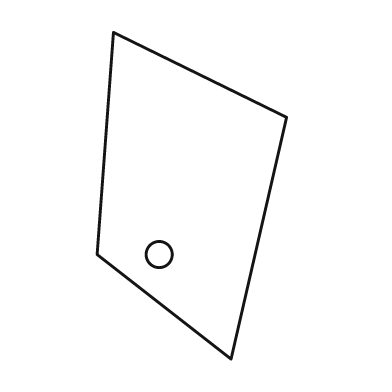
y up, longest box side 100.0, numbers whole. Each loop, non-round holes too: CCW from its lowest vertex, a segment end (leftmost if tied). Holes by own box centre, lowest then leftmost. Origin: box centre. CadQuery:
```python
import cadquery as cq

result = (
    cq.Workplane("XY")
    .moveTo(12.0, -50.0)
    .lineTo(29.0, 24.0)
    .lineTo(-24.0, 50.0)
    .lineTo(-29.0, -18.0)
    .close()
    .moveTo(-10.0, -18.0)
    .circle(4.0)
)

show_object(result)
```